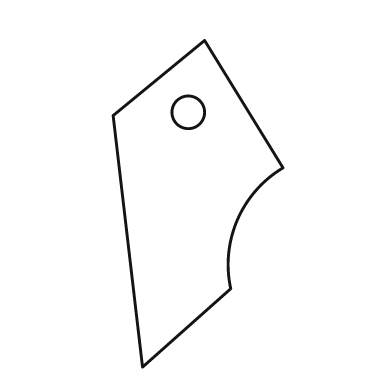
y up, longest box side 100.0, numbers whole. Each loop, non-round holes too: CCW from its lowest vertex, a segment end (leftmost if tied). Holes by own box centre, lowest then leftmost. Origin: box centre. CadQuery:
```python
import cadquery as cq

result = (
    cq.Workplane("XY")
    .moveTo(-17.0, -50.0)
    .lineTo(10.0, -26.0)
    .threePointArc((12.0, -5.0), (26.0, 11.0))
    .lineTo(2.0, 50.0)
    .lineTo(-26.0, 27.0)
    .close()
    .moveTo(-3.0, 28.0)
    .circle(5.0)
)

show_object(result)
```